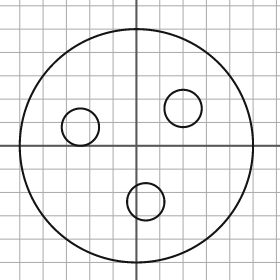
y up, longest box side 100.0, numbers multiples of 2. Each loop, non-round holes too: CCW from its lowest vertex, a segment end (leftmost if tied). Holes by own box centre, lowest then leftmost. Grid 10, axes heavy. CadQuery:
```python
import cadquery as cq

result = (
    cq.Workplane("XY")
    .moveTo(0.0, 0.0)
    .circle(50.0)
    .moveTo(4.0, -24.0)
    .circle(8.0)
    .moveTo(-24.0, 8.0)
    .circle(8.0)
    .moveTo(20.0, 16.0)
    .circle(8.0)
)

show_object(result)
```